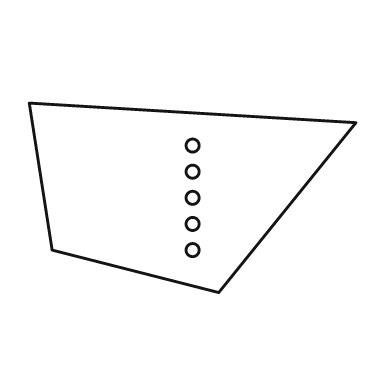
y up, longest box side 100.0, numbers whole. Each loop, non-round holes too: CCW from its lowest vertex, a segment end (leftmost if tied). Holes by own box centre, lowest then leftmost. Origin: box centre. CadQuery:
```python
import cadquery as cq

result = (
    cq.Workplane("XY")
    .moveTo(8.0, -29.0)
    .lineTo(50.0, 23.0)
    .lineTo(-50.0, 29.0)
    .lineTo(-43.0, -16.0)
    .close()
    .moveTo(0.0, -16.0)
    .circle(2.0)
    .moveTo(0.0, -8.0)
    .circle(2.0)
    .moveTo(0.0, 0.0)
    .circle(2.0)
    .moveTo(0.0, 8.0)
    .circle(2.0)
    .moveTo(0.0, 16.0)
    .circle(2.0)
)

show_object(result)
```